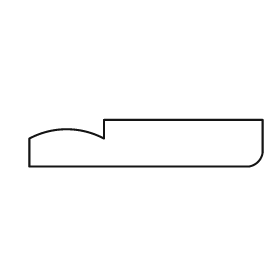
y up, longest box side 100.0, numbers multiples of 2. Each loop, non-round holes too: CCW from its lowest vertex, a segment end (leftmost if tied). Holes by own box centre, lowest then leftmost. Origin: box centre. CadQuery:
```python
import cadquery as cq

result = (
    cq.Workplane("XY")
    .moveTo(-50.0, -10.0)
    .lineTo(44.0, -10.0)
    .threePointArc((48.0, -8.0), (50.0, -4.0))
    .lineTo(50.0, 10.0)
    .lineTo(-18.0, 10.0)
    .lineTo(-18.0, 2.0)
    .threePointArc((-34.0, 6.0), (-50.0, 2.0))
    .close()
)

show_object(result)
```